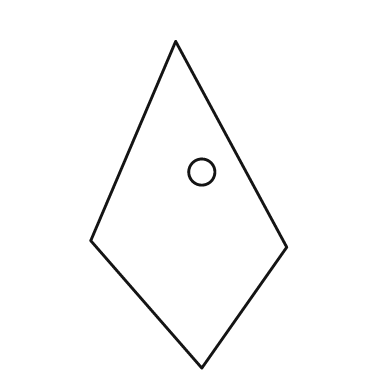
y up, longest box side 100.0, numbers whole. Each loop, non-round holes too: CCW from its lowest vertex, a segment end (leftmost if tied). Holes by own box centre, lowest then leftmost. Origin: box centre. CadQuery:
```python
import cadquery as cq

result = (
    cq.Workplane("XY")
    .moveTo(4.0, -50.0)
    .lineTo(30.0, -13.0)
    .lineTo(-4.0, 50.0)
    .lineTo(-30.0, -11.0)
    .close()
    .moveTo(4.0, 10.0)
    .circle(4.0)
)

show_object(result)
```